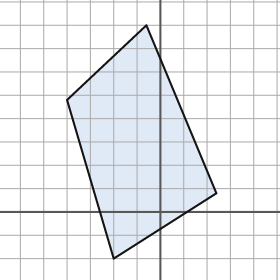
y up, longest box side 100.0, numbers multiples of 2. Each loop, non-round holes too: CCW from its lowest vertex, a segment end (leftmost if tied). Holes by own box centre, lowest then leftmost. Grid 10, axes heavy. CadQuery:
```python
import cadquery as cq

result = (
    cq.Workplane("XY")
    .moveTo(-20.0, -20.0)
    .lineTo(24.0, 8.0)
    .lineTo(-6.0, 80.0)
    .lineTo(-40.0, 48.0)
    .close()
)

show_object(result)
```